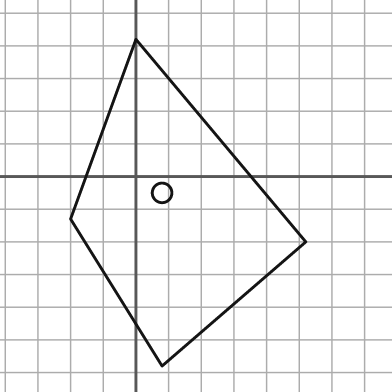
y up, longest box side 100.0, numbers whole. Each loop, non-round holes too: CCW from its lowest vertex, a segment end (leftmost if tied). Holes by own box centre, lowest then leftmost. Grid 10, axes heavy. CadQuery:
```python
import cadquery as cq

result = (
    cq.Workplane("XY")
    .moveTo(8.0, -58.0)
    .lineTo(52.0, -20.0)
    .lineTo(0.0, 42.0)
    .lineTo(-20.0, -13.0)
    .close()
    .moveTo(8.0, -5.0)
    .circle(3.0)
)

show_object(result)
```